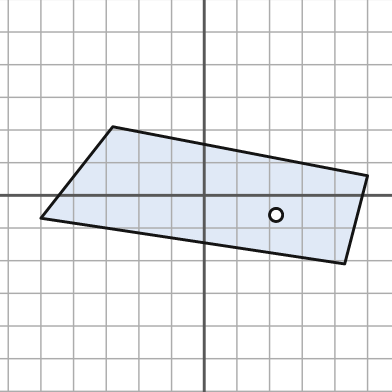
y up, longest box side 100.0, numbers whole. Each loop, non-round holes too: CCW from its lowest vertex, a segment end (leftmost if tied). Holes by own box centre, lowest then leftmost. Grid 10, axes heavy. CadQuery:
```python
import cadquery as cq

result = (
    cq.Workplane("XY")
    .moveTo(43.0, -21.0)
    .lineTo(50.0, 6.0)
    .lineTo(-28.0, 21.0)
    .lineTo(-50.0, -7.0)
    .close()
    .moveTo(22.0, -6.0)
    .circle(2.0)
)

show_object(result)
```